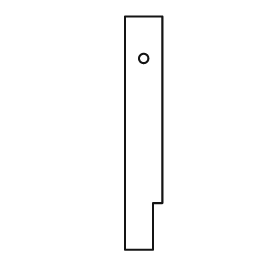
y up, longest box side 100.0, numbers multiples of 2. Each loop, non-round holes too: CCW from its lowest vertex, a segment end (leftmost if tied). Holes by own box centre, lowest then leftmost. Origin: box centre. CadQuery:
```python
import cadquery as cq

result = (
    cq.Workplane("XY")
    .moveTo(-8.0, -50.0)
    .lineTo(4.0, -50.0)
    .lineTo(4.0, -30.0)
    .lineTo(8.0, -30.0)
    .lineTo(8.0, 50.0)
    .lineTo(-8.0, 50.0)
    .close()
    .moveTo(0.0, 32.0)
    .circle(2.0)
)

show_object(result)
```